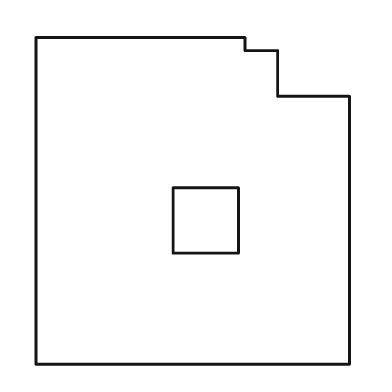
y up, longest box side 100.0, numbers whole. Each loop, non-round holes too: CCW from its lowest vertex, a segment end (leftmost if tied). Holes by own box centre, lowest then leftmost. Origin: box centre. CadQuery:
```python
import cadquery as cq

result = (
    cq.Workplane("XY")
    .moveTo(-48.0, -50.0)
    .lineTo(48.0, -50.0)
    .lineTo(48.0, 32.0)
    .lineTo(26.0, 32.0)
    .lineTo(26.0, 46.0)
    .lineTo(16.0, 46.0)
    .lineTo(16.0, 50.0)
    .lineTo(-48.0, 50.0)
    .close()
    .moveTo(-6.0, -16.0)
    .lineTo(14.0, -16.0)
    .lineTo(14.0, 4.0)
    .lineTo(-6.0, 4.0)
    .close()
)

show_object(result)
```